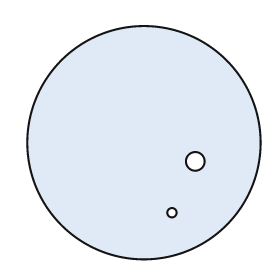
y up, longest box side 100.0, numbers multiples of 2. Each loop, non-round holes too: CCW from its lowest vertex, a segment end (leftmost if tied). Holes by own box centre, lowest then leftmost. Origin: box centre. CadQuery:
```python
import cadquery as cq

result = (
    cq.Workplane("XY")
    .moveTo(0.0, 0.0)
    .circle(50.0)
    .moveTo(12.0, -30.0)
    .circle(2.0)
    .moveTo(22.0, -8.0)
    .circle(4.0)
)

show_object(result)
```